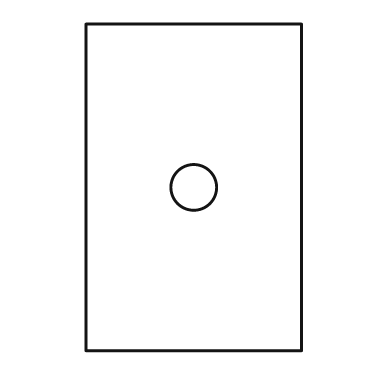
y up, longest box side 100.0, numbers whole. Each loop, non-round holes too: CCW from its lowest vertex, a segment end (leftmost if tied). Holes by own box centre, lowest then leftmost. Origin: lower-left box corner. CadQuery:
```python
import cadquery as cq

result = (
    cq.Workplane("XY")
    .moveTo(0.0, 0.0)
    .lineTo(66.0, 0.0)
    .lineTo(66.0, 100.0)
    .lineTo(0.0, 100.0)
    .close()
    .moveTo(33.0, 50.0)
    .circle(7.0)
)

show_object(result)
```